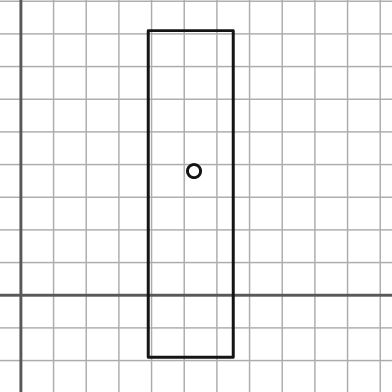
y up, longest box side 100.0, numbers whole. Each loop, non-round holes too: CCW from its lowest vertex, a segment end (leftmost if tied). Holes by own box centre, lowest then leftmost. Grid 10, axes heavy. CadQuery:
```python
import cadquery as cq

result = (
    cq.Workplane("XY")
    .moveTo(39.0, -19.0)
    .lineTo(65.0, -19.0)
    .lineTo(65.0, 81.0)
    .lineTo(39.0, 81.0)
    .close()
    .moveTo(53.0, 38.0)
    .circle(2.0)
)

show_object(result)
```